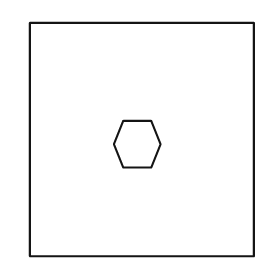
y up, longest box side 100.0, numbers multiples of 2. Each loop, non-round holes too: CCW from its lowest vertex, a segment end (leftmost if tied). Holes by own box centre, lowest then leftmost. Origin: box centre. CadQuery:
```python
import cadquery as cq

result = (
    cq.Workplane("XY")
    .moveTo(-48.0, -50.0)
    .lineTo(48.0, -50.0)
    .lineTo(48.0, 50.0)
    .lineTo(-48.0, 50.0)
    .close()
    .moveTo(-8.0, -12.0)
    .lineTo(4.0, -12.0)
    .lineTo(8.0, -2.0)
    .lineTo(4.0, 8.0)
    .lineTo(-8.0, 8.0)
    .lineTo(-12.0, -2.0)
    .close()
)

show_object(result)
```